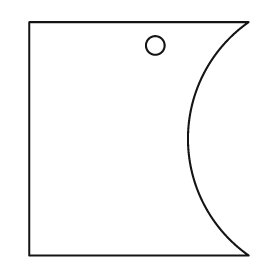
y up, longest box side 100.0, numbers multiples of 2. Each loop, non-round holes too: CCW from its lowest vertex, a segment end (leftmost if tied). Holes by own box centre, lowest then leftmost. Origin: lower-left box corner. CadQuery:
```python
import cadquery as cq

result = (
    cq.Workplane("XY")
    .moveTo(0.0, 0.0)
    .lineTo(94.0, 0.0)
    .threePointArc((68.0, 50.0), (94.0, 100.0))
    .lineTo(0.0, 100.0)
    .close()
    .moveTo(54.0, 90.0)
    .circle(4.0)
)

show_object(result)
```